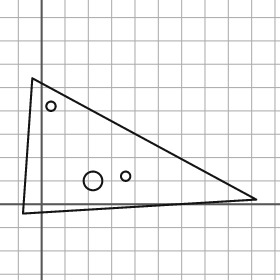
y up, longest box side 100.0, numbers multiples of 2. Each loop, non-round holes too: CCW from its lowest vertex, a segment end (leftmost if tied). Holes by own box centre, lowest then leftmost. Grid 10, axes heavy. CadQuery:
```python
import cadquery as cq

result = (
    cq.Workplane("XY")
    .moveTo(-8.0, -4.0)
    .lineTo(92.0, 2.0)
    .lineTo(-4.0, 54.0)
    .close()
    .moveTo(22.0, 10.0)
    .circle(4.0)
    .moveTo(36.0, 12.0)
    .circle(2.0)
    .moveTo(4.0, 42.0)
    .circle(2.0)
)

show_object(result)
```